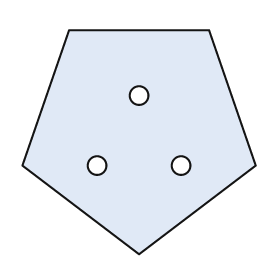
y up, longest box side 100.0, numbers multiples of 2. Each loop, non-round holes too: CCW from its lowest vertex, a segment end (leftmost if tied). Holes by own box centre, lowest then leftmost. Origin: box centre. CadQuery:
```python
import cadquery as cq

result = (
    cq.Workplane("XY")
    .moveTo(0.0, -48.0)
    .lineTo(50.0, -10.0)
    .lineTo(30.0, 48.0)
    .lineTo(-30.0, 48.0)
    .lineTo(-50.0, -10.0)
    .close()
    .moveTo(-18.0, -10.0)
    .circle(4.0)
    .moveTo(18.0, -10.0)
    .circle(4.0)
    .moveTo(0.0, 20.0)
    .circle(4.0)
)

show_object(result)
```